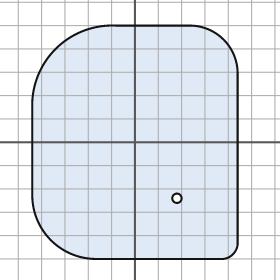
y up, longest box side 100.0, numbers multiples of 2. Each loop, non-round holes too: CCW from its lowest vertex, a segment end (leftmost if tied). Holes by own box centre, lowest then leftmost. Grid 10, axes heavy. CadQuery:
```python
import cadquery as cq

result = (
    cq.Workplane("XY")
    .moveTo(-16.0, -50.0)
    .lineTo(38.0, -50.0)
    .threePointArc((42.0, -48.0), (44.0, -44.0))
    .lineTo(44.0, 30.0)
    .threePointArc((38.0, 44.0), (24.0, 50.0))
    .lineTo(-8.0, 50.0)
    .threePointArc((-34.0, 40.0), (-44.0, 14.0))
    .lineTo(-44.0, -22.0)
    .threePointArc((-36.0, -42.0), (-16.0, -50.0))
    .close()
    .moveTo(18.0, -24.0)
    .circle(2.0)
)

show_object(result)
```